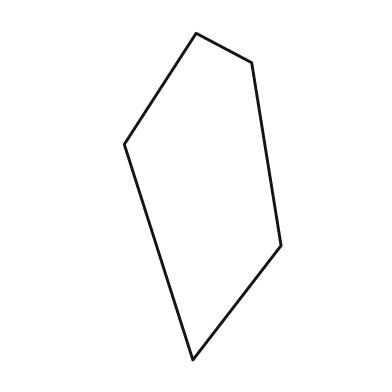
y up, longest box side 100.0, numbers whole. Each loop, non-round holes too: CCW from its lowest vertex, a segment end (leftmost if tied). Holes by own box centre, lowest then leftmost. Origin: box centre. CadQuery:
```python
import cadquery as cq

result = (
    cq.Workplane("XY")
    .moveTo(-3.0, -50.0)
    .lineTo(24.0, -15.0)
    .lineTo(15.0, 41.0)
    .lineTo(-2.0, 50.0)
    .lineTo(-24.0, 16.0)
    .close()
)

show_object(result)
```